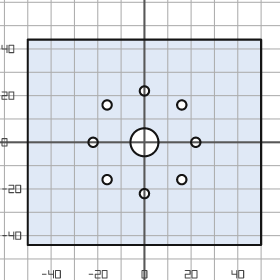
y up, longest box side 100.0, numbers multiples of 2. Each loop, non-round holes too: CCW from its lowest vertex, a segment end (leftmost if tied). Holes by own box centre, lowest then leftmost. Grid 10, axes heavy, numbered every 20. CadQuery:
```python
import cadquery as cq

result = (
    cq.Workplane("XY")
    .moveTo(-50.0, -44.0)
    .lineTo(50.0, -44.0)
    .lineTo(50.0, 44.0)
    .lineTo(-50.0, 44.0)
    .close()
    .moveTo(0.0, -22.0)
    .circle(2.0)
    .moveTo(-16.0, -16.0)
    .circle(2.0)
    .moveTo(16.0, -16.0)
    .circle(2.0)
    .moveTo(-22.0, 0.0)
    .circle(2.0)
    .moveTo(0.0, 0.0)
    .circle(6.0)
    .moveTo(22.0, 0.0)
    .circle(2.0)
    .moveTo(-16.0, 16.0)
    .circle(2.0)
    .moveTo(16.0, 16.0)
    .circle(2.0)
    .moveTo(0.0, 22.0)
    .circle(2.0)
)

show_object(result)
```